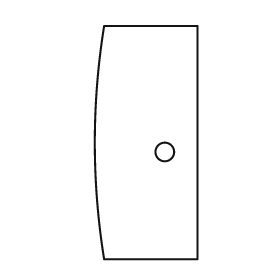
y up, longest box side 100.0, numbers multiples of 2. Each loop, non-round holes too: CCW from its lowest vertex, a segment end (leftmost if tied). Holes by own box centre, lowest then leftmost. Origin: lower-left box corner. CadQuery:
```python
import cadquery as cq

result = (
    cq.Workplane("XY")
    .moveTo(4.0, 0.0)
    .lineTo(44.0, 0.0)
    .lineTo(44.0, 100.0)
    .lineTo(4.0, 100.0)
    .threePointArc((0.0, 50.0), (4.0, 0.0))
    .close()
    .moveTo(30.0, 46.0)
    .circle(4.0)
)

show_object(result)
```